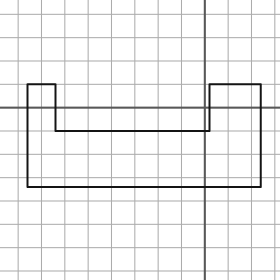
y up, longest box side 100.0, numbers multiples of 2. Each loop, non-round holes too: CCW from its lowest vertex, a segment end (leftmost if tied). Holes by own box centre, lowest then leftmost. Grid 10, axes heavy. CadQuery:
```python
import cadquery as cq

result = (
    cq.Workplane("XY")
    .moveTo(-76.0, -34.0)
    .lineTo(24.0, -34.0)
    .lineTo(24.0, 10.0)
    .lineTo(2.0, 10.0)
    .lineTo(2.0, -10.0)
    .lineTo(-64.0, -10.0)
    .lineTo(-64.0, 10.0)
    .lineTo(-76.0, 10.0)
    .close()
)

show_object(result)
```